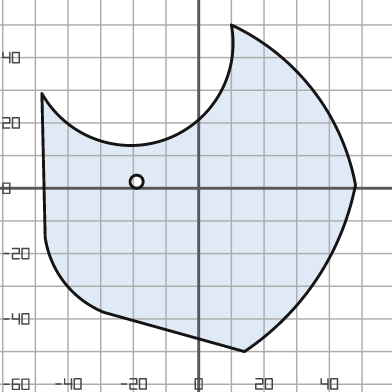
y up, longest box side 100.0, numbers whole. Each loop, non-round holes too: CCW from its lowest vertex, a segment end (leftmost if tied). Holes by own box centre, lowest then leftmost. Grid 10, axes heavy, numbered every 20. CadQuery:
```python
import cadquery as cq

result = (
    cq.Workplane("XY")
    .moveTo(14.0, -50.0)
    .threePointArc((36.0, -28.0), (48.0, 1.0))
    .threePointArc((35.0, 30.0), (10.0, 50.0))
    .threePointArc((-10.0, 15.0), (-48.0, 29.0))
    .lineTo(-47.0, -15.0)
    .threePointArc((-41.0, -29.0), (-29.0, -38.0))
    .close()
    .moveTo(-19.0, 2.0)
    .circle(2.0)
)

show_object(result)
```